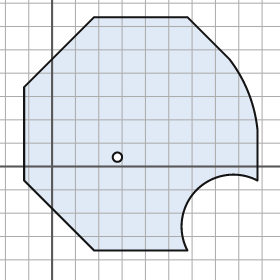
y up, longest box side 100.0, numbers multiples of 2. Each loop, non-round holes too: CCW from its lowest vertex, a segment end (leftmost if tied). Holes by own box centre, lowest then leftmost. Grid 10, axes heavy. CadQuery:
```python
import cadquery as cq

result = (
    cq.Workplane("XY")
    .moveTo(18.0, -36.0)
    .lineTo(58.0, -36.0)
    .threePointArc((62.0, -10.0), (88.0, -6.0))
    .lineTo(88.0, 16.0)
    .threePointArc((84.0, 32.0), (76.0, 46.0))
    .lineTo(58.0, 64.0)
    .lineTo(18.0, 64.0)
    .lineTo(-12.0, 34.0)
    .lineTo(-12.0, -6.0)
    .close()
    .moveTo(28.0, 4.0)
    .circle(2.0)
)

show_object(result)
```